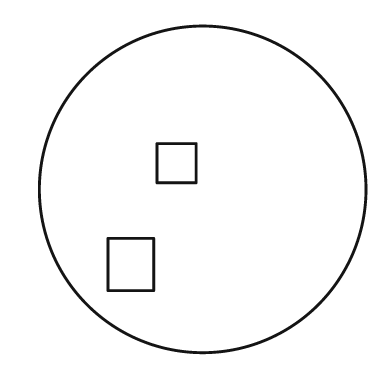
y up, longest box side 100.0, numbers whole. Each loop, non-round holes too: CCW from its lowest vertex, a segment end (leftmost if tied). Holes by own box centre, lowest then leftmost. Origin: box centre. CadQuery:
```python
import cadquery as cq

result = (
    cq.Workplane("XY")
    .moveTo(0.0, 0.0)
    .circle(50.0)
    .moveTo(-29.0, -31.0)
    .lineTo(-15.0, -31.0)
    .lineTo(-15.0, -15.0)
    .lineTo(-29.0, -15.0)
    .close()
    .moveTo(-14.0, 2.0)
    .lineTo(-2.0, 2.0)
    .lineTo(-2.0, 14.0)
    .lineTo(-14.0, 14.0)
    .close()
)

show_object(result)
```